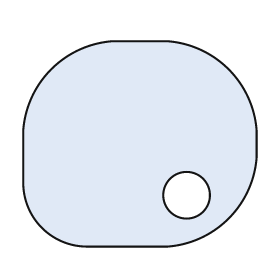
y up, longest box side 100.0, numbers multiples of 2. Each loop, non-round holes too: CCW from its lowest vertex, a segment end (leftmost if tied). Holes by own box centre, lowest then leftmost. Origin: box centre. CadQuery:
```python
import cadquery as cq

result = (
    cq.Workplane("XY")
    .moveTo(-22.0, -44.0)
    .lineTo(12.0, -44.0)
    .threePointArc((38.0, -32.0), (50.0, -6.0))
    .lineTo(50.0, 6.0)
    .threePointArc((38.0, 32.0), (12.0, 44.0))
    .lineTo(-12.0, 44.0)
    .threePointArc((-38.0, 32.0), (-50.0, 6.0))
    .lineTo(-50.0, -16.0)
    .threePointArc((-42.0, -36.0), (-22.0, -44.0))
    .close()
    .moveTo(20.0, -22.0)
    .circle(10.0)
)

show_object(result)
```